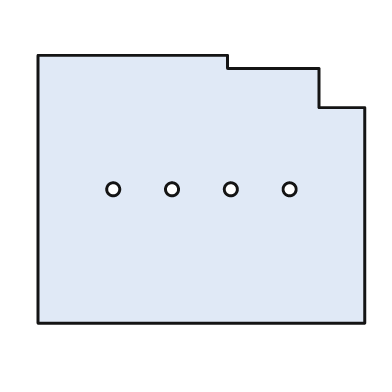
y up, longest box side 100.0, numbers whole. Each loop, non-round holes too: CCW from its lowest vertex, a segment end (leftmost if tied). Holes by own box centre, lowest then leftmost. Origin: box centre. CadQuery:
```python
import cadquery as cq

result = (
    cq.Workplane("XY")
    .moveTo(-50.0, -41.0)
    .lineTo(50.0, -41.0)
    .lineTo(50.0, 25.0)
    .lineTo(36.0, 25.0)
    .lineTo(36.0, 37.0)
    .lineTo(8.0, 37.0)
    .lineTo(8.0, 41.0)
    .lineTo(-50.0, 41.0)
    .close()
    .moveTo(-27.0, 0.0)
    .circle(2.0)
    .moveTo(-9.0, 0.0)
    .circle(2.0)
    .moveTo(9.0, 0.0)
    .circle(2.0)
    .moveTo(27.0, 0.0)
    .circle(2.0)
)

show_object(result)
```